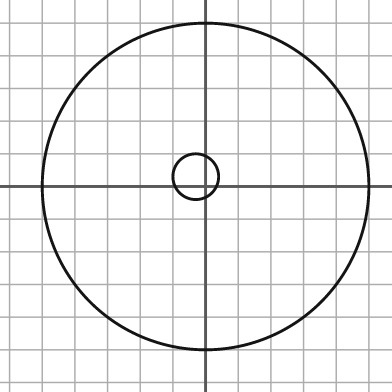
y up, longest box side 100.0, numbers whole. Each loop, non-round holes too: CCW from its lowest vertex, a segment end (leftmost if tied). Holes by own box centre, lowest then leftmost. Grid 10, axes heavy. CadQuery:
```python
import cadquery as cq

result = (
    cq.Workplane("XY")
    .moveTo(0.0, 0.0)
    .circle(50.0)
    .moveTo(-3.0, 3.0)
    .circle(7.0)
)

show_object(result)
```